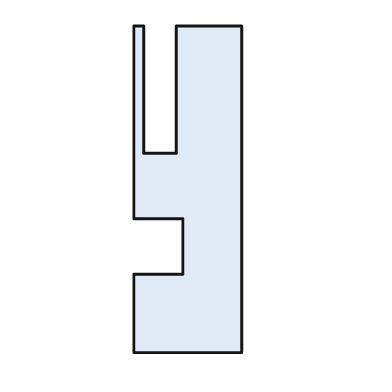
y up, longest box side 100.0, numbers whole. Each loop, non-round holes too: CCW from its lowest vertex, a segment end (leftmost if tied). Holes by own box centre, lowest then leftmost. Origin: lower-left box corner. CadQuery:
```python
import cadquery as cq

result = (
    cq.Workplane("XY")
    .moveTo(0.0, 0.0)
    .lineTo(33.0, 0.0)
    .lineTo(33.0, 100.0)
    .lineTo(13.0, 100.0)
    .lineTo(13.0, 61.0)
    .lineTo(3.0, 61.0)
    .lineTo(3.0, 100.0)
    .lineTo(0.0, 100.0)
    .lineTo(0.0, 41.0)
    .lineTo(15.0, 41.0)
    .lineTo(15.0, 24.0)
    .lineTo(0.0, 24.0)
    .close()
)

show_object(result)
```